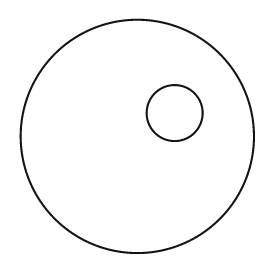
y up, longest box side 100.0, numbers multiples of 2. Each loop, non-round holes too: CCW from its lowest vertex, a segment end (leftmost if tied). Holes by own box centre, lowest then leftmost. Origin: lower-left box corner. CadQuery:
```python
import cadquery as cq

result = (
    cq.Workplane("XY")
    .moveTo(50.0, 50.0)
    .circle(50.0)
    .moveTo(66.0, 60.0)
    .circle(12.0)
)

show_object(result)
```